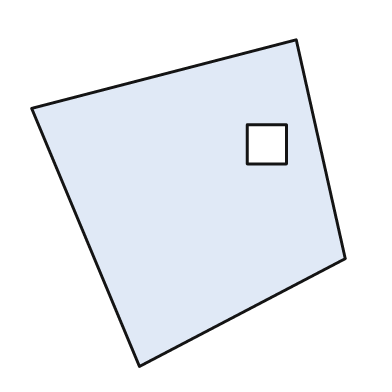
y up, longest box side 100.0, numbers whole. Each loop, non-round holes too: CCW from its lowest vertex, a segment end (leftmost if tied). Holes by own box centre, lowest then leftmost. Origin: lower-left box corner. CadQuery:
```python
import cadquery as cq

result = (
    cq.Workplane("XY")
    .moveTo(33.0, 0.0)
    .lineTo(96.0, 33.0)
    .lineTo(81.0, 100.0)
    .lineTo(0.0, 79.0)
    .close()
    .moveTo(66.0, 62.0)
    .lineTo(78.0, 62.0)
    .lineTo(78.0, 74.0)
    .lineTo(66.0, 74.0)
    .close()
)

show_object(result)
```